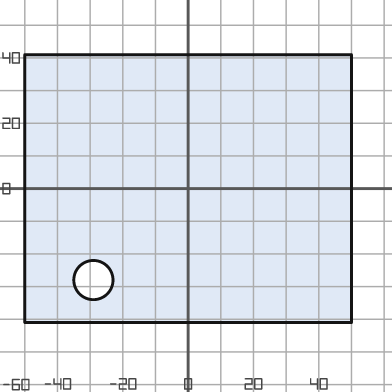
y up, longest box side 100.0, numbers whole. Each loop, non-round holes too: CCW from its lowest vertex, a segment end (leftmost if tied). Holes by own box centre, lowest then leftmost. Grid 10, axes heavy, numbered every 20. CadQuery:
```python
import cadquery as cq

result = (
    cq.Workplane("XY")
    .moveTo(-50.0, -41.0)
    .lineTo(50.0, -41.0)
    .lineTo(50.0, 41.0)
    .lineTo(-50.0, 41.0)
    .close()
    .moveTo(-29.0, -28.0)
    .circle(6.0)
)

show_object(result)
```